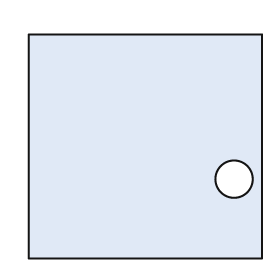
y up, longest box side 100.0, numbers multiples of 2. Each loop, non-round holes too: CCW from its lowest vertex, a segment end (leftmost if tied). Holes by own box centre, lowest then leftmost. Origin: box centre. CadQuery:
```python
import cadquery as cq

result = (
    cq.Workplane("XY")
    .moveTo(-50.0, -48.0)
    .lineTo(50.0, -48.0)
    .lineTo(50.0, 48.0)
    .lineTo(-50.0, 48.0)
    .close()
    .moveTo(38.0, -14.0)
    .circle(8.0)
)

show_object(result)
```